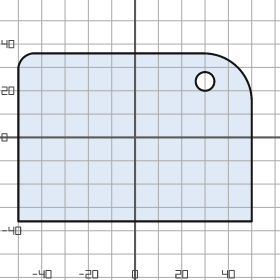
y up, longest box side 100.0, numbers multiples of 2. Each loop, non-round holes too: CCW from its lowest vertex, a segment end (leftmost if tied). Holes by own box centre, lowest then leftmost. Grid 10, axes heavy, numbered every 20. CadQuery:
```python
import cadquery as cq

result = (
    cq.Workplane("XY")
    .moveTo(-50.0, -36.0)
    .lineTo(50.0, -36.0)
    .lineTo(50.0, 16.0)
    .threePointArc((44.0, 30.0), (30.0, 36.0))
    .lineTo(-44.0, 36.0)
    .threePointArc((-48.0, 34.0), (-50.0, 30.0))
    .close()
    .moveTo(30.0, 24.0)
    .circle(4.0)
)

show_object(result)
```